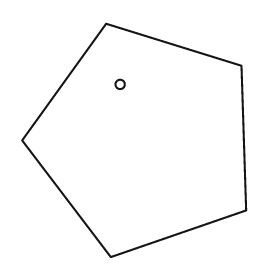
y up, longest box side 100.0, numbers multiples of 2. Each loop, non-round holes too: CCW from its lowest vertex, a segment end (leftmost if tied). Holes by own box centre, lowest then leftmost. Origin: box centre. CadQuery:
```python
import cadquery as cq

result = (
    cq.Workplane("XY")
    .moveTo(-10.0, -50.0)
    .lineTo(48.0, -30.0)
    .lineTo(46.0, 32.0)
    .lineTo(-12.0, 50.0)
    .lineTo(-48.0, 0.0)
    .close()
    .moveTo(-6.0, 24.0)
    .circle(2.0)
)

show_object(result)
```